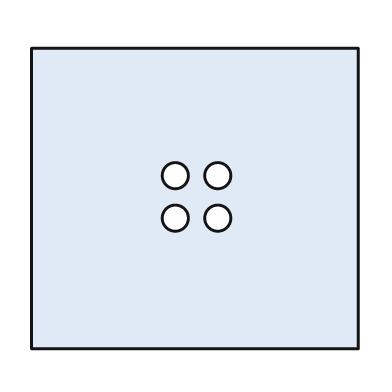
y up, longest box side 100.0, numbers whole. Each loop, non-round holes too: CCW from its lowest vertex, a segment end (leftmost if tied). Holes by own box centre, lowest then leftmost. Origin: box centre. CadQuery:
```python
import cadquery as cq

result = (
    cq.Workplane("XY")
    .moveTo(-50.0, -46.0)
    .lineTo(50.0, -46.0)
    .lineTo(50.0, 46.0)
    .lineTo(-50.0, 46.0)
    .close()
    .moveTo(-6.0, -6.0)
    .circle(4.0)
    .moveTo(7.0, -6.0)
    .circle(4.0)
    .moveTo(-6.0, 7.0)
    .circle(4.0)
    .moveTo(7.0, 7.0)
    .circle(4.0)
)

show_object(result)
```